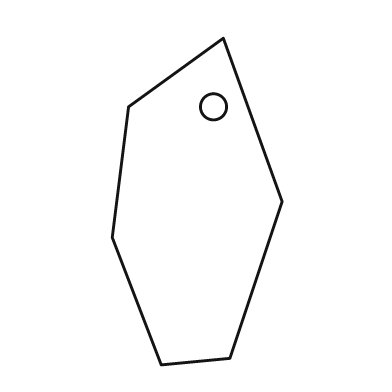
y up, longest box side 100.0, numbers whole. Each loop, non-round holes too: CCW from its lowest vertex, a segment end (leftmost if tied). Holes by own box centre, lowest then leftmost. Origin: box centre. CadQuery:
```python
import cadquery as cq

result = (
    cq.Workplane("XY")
    .moveTo(-11.0, -50.0)
    .lineTo(10.0, -48.0)
    .lineTo(26.0, 0.0)
    .lineTo(8.0, 50.0)
    .lineTo(-21.0, 29.0)
    .lineTo(-26.0, -11.0)
    .close()
    .moveTo(5.0, 29.0)
    .circle(4.0)
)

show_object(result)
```